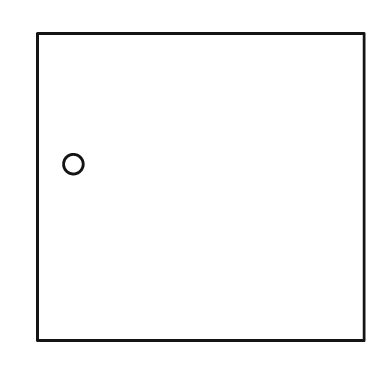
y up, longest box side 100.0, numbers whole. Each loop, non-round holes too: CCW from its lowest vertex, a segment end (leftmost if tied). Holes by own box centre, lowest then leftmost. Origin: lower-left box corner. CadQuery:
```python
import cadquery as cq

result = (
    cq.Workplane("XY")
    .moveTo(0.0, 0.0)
    .lineTo(100.0, 0.0)
    .lineTo(100.0, 94.0)
    .lineTo(0.0, 94.0)
    .close()
    .moveTo(11.0, 54.0)
    .circle(3.0)
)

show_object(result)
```